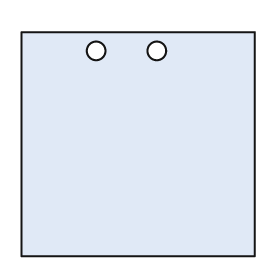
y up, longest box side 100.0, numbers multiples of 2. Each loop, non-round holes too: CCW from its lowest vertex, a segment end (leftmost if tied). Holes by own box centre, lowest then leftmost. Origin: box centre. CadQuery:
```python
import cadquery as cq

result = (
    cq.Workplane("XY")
    .moveTo(-50.0, -48.0)
    .lineTo(50.0, -48.0)
    .lineTo(50.0, 48.0)
    .lineTo(-50.0, 48.0)
    .close()
    .moveTo(-18.0, 40.0)
    .circle(4.0)
    .moveTo(8.0, 40.0)
    .circle(4.0)
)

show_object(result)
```